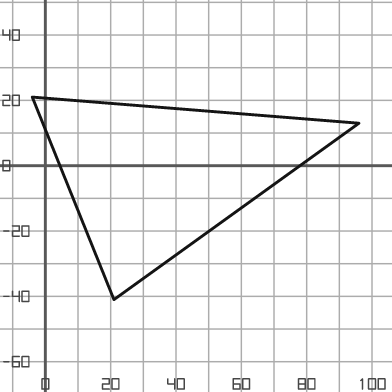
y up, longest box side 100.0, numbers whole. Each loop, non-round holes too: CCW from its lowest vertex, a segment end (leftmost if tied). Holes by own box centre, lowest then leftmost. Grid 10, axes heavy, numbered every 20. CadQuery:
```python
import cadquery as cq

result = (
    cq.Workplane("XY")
    .moveTo(21.0, -41.0)
    .lineTo(96.0, 13.0)
    .lineTo(-4.0, 21.0)
    .close()
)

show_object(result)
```